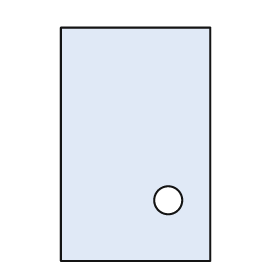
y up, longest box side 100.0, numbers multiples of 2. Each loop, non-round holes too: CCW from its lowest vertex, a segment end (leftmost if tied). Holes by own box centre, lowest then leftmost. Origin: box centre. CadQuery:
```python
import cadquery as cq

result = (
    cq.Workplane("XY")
    .moveTo(-32.0, -50.0)
    .lineTo(32.0, -50.0)
    .lineTo(32.0, 50.0)
    .lineTo(-32.0, 50.0)
    .close()
    .moveTo(14.0, -24.0)
    .circle(6.0)
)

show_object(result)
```